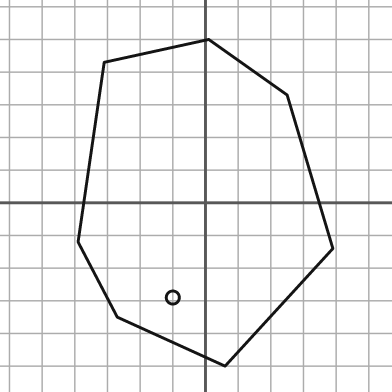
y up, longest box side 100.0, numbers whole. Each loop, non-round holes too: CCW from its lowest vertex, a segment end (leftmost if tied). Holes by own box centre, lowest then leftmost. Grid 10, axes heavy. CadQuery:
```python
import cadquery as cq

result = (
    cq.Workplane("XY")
    .moveTo(6.0, -50.0)
    .lineTo(39.0, -14.0)
    .lineTo(25.0, 33.0)
    .lineTo(1.0, 50.0)
    .lineTo(-31.0, 43.0)
    .lineTo(-39.0, -12.0)
    .lineTo(-27.0, -35.0)
    .close()
    .moveTo(-10.0, -29.0)
    .circle(2.0)
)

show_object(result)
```